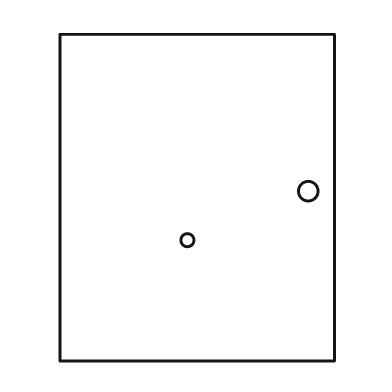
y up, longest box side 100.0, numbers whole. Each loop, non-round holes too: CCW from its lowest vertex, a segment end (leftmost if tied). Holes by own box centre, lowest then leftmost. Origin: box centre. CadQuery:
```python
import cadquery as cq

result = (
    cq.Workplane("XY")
    .moveTo(-42.0, -50.0)
    .lineTo(42.0, -50.0)
    .lineTo(42.0, 50.0)
    .lineTo(-42.0, 50.0)
    .close()
    .moveTo(-3.0, -13.0)
    .circle(2.0)
    .moveTo(34.0, 2.0)
    .circle(3.0)
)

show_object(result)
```